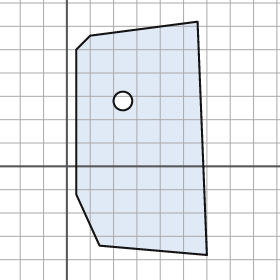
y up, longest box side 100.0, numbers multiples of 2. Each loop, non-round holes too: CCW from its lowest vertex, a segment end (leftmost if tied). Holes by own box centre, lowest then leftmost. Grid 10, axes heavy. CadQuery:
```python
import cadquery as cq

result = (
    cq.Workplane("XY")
    .moveTo(60.0, -38.0)
    .lineTo(56.0, 62.0)
    .lineTo(10.0, 56.0)
    .lineTo(4.0, 50.0)
    .lineTo(4.0, -12.0)
    .lineTo(14.0, -34.0)
    .close()
    .moveTo(24.0, 28.0)
    .circle(4.0)
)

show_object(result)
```